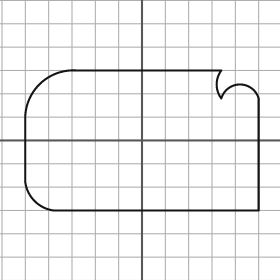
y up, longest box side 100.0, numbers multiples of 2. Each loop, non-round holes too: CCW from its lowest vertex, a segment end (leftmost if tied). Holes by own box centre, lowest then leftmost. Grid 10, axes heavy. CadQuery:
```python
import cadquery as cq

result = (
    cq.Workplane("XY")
    .moveTo(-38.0, -30.0)
    .lineTo(50.0, -30.0)
    .lineTo(50.0, 18.0)
    .threePointArc((42.0, 24.0), (34.0, 18.0))
    .threePointArc((32.0, 24.0), (34.0, 30.0))
    .lineTo(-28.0, 30.0)
    .threePointArc((-44.0, 24.0), (-50.0, 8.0))
    .lineTo(-50.0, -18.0)
    .threePointArc((-46.0, -26.0), (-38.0, -30.0))
    .close()
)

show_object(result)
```